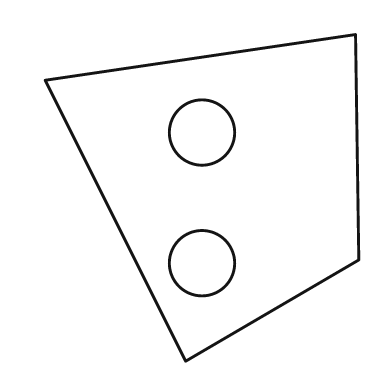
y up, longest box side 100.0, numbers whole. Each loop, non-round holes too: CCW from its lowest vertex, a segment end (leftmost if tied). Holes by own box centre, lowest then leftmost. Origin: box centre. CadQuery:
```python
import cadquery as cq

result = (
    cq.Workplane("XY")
    .moveTo(-5.0, -50.0)
    .lineTo(48.0, -19.0)
    .lineTo(47.0, 50.0)
    .lineTo(-48.0, 36.0)
    .close()
    .moveTo(0.0, -20.0)
    .circle(10.0)
    .moveTo(0.0, 20.0)
    .circle(10.0)
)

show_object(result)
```